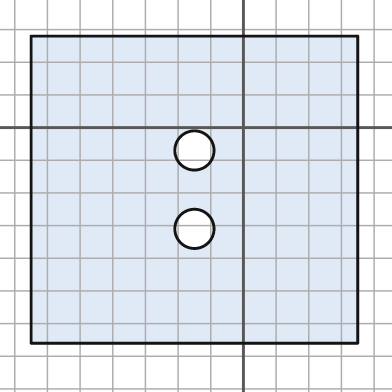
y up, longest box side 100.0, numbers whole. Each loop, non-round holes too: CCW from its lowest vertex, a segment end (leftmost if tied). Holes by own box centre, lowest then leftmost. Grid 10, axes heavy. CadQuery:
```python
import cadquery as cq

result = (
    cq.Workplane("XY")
    .moveTo(-65.0, -66.0)
    .lineTo(35.0, -66.0)
    .lineTo(35.0, 28.0)
    .lineTo(-65.0, 28.0)
    .close()
    .moveTo(-15.0, -31.0)
    .circle(6.0)
    .moveTo(-15.0, -7.0)
    .circle(6.0)
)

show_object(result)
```